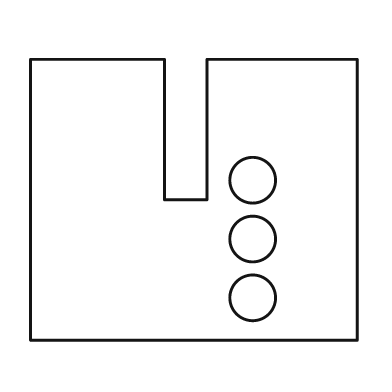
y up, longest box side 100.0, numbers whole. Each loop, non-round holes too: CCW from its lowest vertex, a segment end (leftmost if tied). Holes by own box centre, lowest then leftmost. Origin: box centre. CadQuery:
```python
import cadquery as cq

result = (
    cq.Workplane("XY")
    .moveTo(-50.0, -43.0)
    .lineTo(50.0, -43.0)
    .lineTo(50.0, 43.0)
    .lineTo(4.0, 43.0)
    .lineTo(4.0, 0.0)
    .lineTo(-9.0, 0.0)
    .lineTo(-9.0, 43.0)
    .lineTo(-50.0, 43.0)
    .close()
    .moveTo(18.0, -30.0)
    .circle(7.0)
    .moveTo(18.0, -12.0)
    .circle(7.0)
    .moveTo(18.0, 6.0)
    .circle(7.0)
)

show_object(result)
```